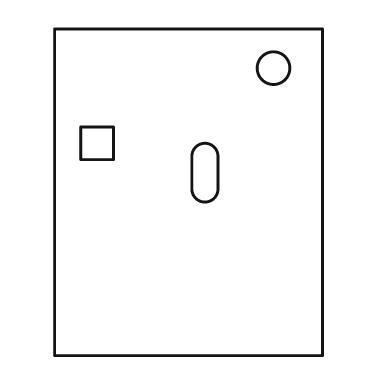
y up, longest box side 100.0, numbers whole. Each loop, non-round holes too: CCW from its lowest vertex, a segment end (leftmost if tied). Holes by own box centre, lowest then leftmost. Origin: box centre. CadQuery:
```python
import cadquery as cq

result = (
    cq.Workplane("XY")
    .moveTo(-41.0, -50.0)
    .lineTo(41.0, -50.0)
    .lineTo(41.0, 50.0)
    .lineTo(-41.0, 50.0)
    .close()
    .moveTo(1.0, 1.0)
    .threePointArc((5.0, -3.0), (9.0, 1.0))
    .lineTo(9.0, 11.0)
    .threePointArc((5.0, 15.0), (1.0, 11.0))
    .close()
    .moveTo(-33.0, 10.0)
    .lineTo(-23.0, 10.0)
    .lineTo(-23.0, 20.0)
    .lineTo(-33.0, 20.0)
    .close()
    .moveTo(26.0, 38.0)
    .circle(5.0)
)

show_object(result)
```